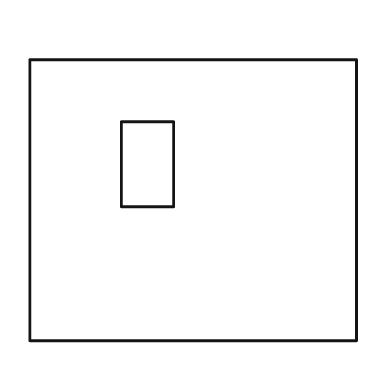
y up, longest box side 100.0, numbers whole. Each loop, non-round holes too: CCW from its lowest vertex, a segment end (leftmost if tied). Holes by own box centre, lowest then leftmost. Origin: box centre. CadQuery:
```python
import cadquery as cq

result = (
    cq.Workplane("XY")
    .moveTo(-50.0, -43.0)
    .lineTo(50.0, -43.0)
    .lineTo(50.0, 43.0)
    .lineTo(-50.0, 43.0)
    .close()
    .moveTo(-22.0, -2.0)
    .lineTo(-6.0, -2.0)
    .lineTo(-6.0, 24.0)
    .lineTo(-22.0, 24.0)
    .close()
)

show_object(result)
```